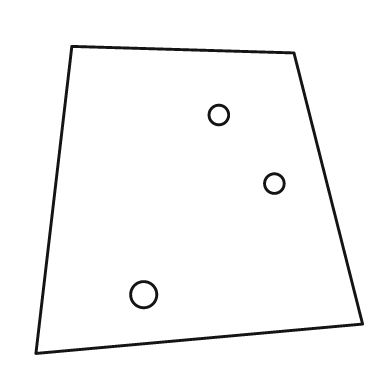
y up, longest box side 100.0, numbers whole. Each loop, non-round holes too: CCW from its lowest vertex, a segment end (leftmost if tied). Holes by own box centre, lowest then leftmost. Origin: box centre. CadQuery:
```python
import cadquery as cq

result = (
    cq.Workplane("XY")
    .moveTo(-50.0, -47.0)
    .lineTo(50.0, -38.0)
    .lineTo(29.0, 45.0)
    .lineTo(-39.0, 47.0)
    .close()
    .moveTo(-17.0, -29.0)
    .circle(4.0)
    .moveTo(23.0, 5.0)
    .circle(3.0)
    .moveTo(6.0, 26.0)
    .circle(3.0)
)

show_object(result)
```